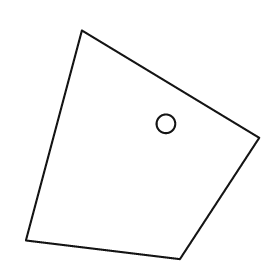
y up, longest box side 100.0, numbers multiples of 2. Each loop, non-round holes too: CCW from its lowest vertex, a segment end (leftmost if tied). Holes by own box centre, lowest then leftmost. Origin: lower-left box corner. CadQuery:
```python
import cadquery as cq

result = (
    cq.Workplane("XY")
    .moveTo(66.0, 0.0)
    .lineTo(100.0, 52.0)
    .lineTo(24.0, 98.0)
    .lineTo(0.0, 8.0)
    .close()
    .moveTo(60.0, 58.0)
    .circle(4.0)
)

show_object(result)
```